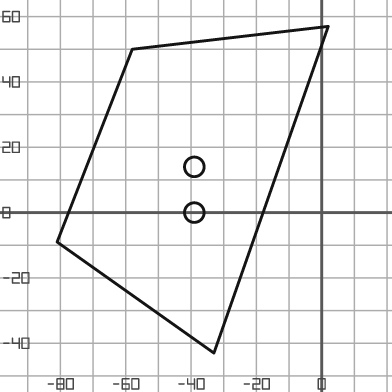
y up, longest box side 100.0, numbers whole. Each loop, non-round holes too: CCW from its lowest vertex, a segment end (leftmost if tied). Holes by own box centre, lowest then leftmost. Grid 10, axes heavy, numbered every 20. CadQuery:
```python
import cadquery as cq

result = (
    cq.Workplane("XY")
    .moveTo(-33.0, -43.0)
    .lineTo(2.0, 57.0)
    .lineTo(-58.0, 50.0)
    .lineTo(-81.0, -9.0)
    .close()
    .moveTo(-39.0, 0.0)
    .circle(3.0)
    .moveTo(-39.0, 14.0)
    .circle(3.0)
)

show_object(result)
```